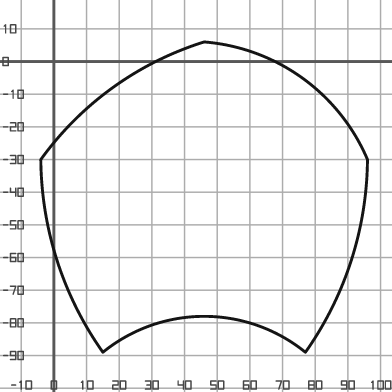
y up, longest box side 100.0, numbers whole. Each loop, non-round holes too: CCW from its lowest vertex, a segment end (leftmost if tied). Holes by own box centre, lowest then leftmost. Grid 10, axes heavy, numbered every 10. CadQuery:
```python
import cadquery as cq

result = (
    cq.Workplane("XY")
    .moveTo(15.0, -89.0)
    .threePointArc((46.0, -78.0), (77.0, -89.0))
    .threePointArc((91.0, -61.0), (96.0, -30.0))
    .threePointArc((76.0, -5.0), (46.0, 6.0))
    .threePointArc((18.0, -8.0), (-4.0, -30.0))
    .threePointArc((1.0, -61.0), (15.0, -89.0))
    .close()
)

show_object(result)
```